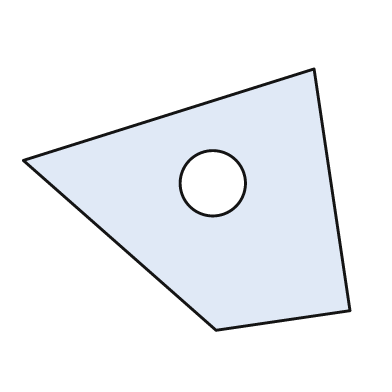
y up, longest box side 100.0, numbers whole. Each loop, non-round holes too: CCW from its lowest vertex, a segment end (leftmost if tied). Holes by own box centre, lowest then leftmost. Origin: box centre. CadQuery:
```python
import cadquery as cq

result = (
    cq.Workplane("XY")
    .moveTo(9.0, -40.0)
    .lineTo(50.0, -34.0)
    .lineTo(39.0, 40.0)
    .lineTo(-50.0, 12.0)
    .close()
    .moveTo(8.0, 5.0)
    .circle(10.0)
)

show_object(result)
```